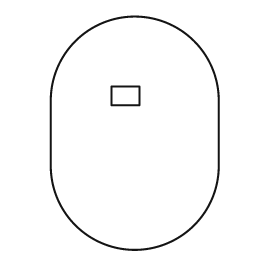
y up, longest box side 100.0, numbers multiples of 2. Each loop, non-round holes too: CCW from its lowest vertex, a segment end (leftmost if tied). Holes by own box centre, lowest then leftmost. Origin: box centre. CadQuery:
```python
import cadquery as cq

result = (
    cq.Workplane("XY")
    .moveTo(-36.0, -14.0)
    .threePointArc((0.0, -50.0), (36.0, -14.0))
    .lineTo(36.0, 14.0)
    .threePointArc((0.0, 50.0), (-36.0, 14.0))
    .close()
    .moveTo(-10.0, 12.0)
    .lineTo(2.0, 12.0)
    .lineTo(2.0, 20.0)
    .lineTo(-10.0, 20.0)
    .close()
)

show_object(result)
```